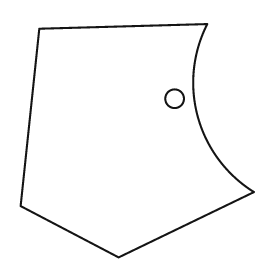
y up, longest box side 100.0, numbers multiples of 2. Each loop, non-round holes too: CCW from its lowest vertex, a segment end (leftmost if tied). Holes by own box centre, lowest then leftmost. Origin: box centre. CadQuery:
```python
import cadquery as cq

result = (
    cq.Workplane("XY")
    .moveTo(-8.0, -50.0)
    .lineTo(50.0, -22.0)
    .threePointArc((26.0, 10.0), (30.0, 50.0))
    .lineTo(-42.0, 48.0)
    .lineTo(-50.0, -28.0)
    .close()
    .moveTo(16.0, 18.0)
    .circle(4.0)
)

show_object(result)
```